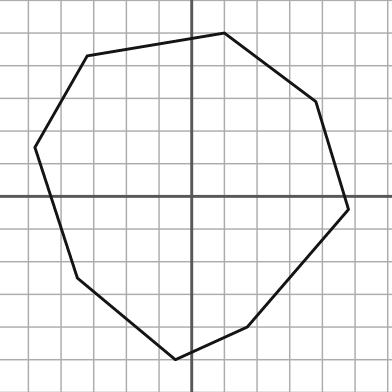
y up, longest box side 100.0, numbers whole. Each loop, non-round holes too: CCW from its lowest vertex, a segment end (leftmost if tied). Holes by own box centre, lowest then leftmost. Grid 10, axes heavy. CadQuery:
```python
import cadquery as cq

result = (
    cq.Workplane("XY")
    .moveTo(-5.0, -50.0)
    .lineTo(17.0, -40.0)
    .lineTo(48.0, -4.0)
    .lineTo(38.0, 29.0)
    .lineTo(10.0, 50.0)
    .lineTo(-32.0, 43.0)
    .lineTo(-48.0, 15.0)
    .lineTo(-35.0, -25.0)
    .close()
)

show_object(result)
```